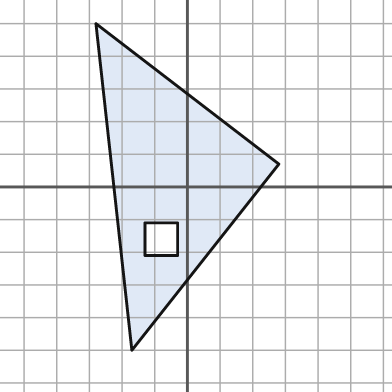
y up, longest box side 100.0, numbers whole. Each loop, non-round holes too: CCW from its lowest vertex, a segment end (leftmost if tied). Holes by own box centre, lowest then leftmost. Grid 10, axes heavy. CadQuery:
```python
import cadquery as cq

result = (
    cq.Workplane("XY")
    .moveTo(-17.0, -50.0)
    .lineTo(28.0, 7.0)
    .lineTo(-28.0, 50.0)
    .close()
    .moveTo(-13.0, -21.0)
    .lineTo(-3.0, -21.0)
    .lineTo(-3.0, -11.0)
    .lineTo(-13.0, -11.0)
    .close()
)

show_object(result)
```